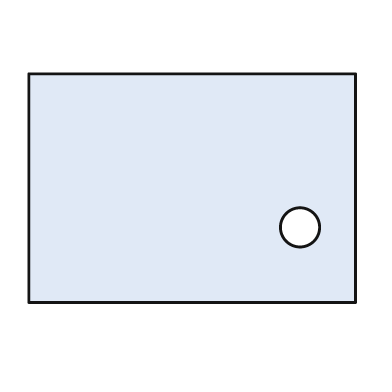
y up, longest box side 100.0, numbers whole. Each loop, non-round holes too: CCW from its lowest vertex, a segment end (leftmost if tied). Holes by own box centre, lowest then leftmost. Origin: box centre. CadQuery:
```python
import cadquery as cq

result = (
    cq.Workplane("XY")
    .moveTo(-50.0, -35.0)
    .lineTo(50.0, -35.0)
    .lineTo(50.0, 35.0)
    .lineTo(-50.0, 35.0)
    .close()
    .moveTo(33.0, -12.0)
    .circle(6.0)
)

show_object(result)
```